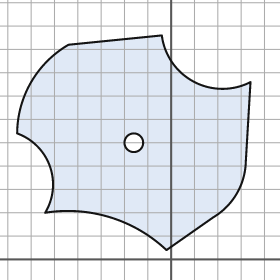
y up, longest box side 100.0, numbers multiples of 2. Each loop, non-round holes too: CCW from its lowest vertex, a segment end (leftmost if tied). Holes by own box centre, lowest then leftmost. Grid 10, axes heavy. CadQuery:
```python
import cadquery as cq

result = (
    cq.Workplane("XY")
    .moveTo(-2.0, 4.0)
    .lineTo(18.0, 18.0)
    .threePointArc((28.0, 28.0), (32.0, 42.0))
    .lineTo(34.0, 76.0)
    .threePointArc((10.0, 76.0), (-4.0, 96.0))
    .lineTo(-44.0, 92.0)
    .threePointArc((-60.0, 76.0), (-66.0, 54.0))
    .threePointArc((-52.0, 40.0), (-54.0, 20.0))
    .threePointArc((-26.0, 18.0), (-2.0, 4.0))
    .close()
    .moveTo(-16.0, 50.0)
    .circle(4.0)
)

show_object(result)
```